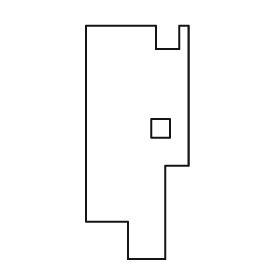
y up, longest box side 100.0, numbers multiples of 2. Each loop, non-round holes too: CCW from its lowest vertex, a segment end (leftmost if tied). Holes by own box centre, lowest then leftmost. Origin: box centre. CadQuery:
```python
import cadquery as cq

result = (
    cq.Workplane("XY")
    .moveTo(-4.0, -50.0)
    .lineTo(12.0, -50.0)
    .lineTo(12.0, -10.0)
    .lineTo(22.0, -10.0)
    .lineTo(22.0, 50.0)
    .lineTo(18.0, 50.0)
    .lineTo(18.0, 40.0)
    .lineTo(8.0, 40.0)
    .lineTo(8.0, 50.0)
    .lineTo(-22.0, 50.0)
    .lineTo(-22.0, -34.0)
    .lineTo(-4.0, -34.0)
    .close()
    .moveTo(6.0, 2.0)
    .lineTo(14.0, 2.0)
    .lineTo(14.0, 10.0)
    .lineTo(6.0, 10.0)
    .close()
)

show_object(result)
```